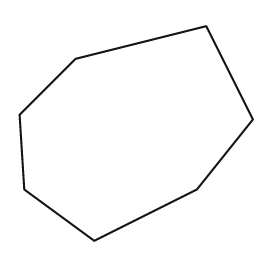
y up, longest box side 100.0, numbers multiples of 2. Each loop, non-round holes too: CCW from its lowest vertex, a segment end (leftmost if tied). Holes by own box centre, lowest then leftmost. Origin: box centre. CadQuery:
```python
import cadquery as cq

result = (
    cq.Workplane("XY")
    .moveTo(-18.0, -46.0)
    .lineTo(26.0, -24.0)
    .lineTo(50.0, 6.0)
    .lineTo(30.0, 46.0)
    .lineTo(-26.0, 32.0)
    .lineTo(-50.0, 8.0)
    .lineTo(-48.0, -24.0)
    .close()
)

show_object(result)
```